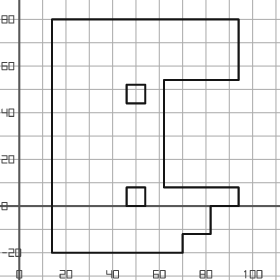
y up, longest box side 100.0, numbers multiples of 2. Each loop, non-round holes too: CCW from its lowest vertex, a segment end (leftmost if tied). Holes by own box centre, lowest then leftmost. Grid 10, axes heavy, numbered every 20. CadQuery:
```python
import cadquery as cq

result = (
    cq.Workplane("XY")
    .moveTo(14.0, -20.0)
    .lineTo(70.0, -20.0)
    .lineTo(70.0, -12.0)
    .lineTo(82.0, -12.0)
    .lineTo(82.0, 0.0)
    .lineTo(94.0, 0.0)
    .lineTo(94.0, 8.0)
    .lineTo(62.0, 8.0)
    .lineTo(62.0, 54.0)
    .lineTo(94.0, 54.0)
    .lineTo(94.0, 80.0)
    .lineTo(14.0, 80.0)
    .close()
    .moveTo(46.0, 0.0)
    .lineTo(54.0, 0.0)
    .lineTo(54.0, 8.0)
    .lineTo(46.0, 8.0)
    .close()
    .moveTo(46.0, 44.0)
    .lineTo(54.0, 44.0)
    .lineTo(54.0, 52.0)
    .lineTo(46.0, 52.0)
    .close()
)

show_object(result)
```